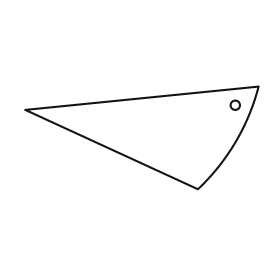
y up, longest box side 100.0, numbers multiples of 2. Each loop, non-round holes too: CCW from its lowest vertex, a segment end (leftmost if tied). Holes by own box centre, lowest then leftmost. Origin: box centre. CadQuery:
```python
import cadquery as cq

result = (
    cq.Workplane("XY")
    .moveTo(24.0, -22.0)
    .threePointArc((40.0, -2.0), (50.0, 22.0))
    .lineTo(-50.0, 12.0)
    .close()
    .moveTo(40.0, 14.0)
    .circle(2.0)
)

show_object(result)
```